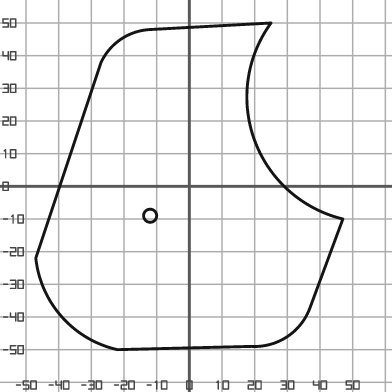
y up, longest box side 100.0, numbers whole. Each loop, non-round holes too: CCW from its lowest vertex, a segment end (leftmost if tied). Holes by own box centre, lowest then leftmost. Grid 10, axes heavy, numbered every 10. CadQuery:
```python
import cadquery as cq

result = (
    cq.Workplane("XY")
    .moveTo(-22.0, -50.0)
    .lineTo(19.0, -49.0)
    .threePointArc((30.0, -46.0), (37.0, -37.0))
    .lineTo(47.0, -10.0)
    .threePointArc((20.0, 14.0), (25.0, 50.0))
    .lineTo(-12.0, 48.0)
    .threePointArc((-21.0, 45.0), (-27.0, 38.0))
    .lineTo(-47.0, -22.0)
    .threePointArc((-39.0, -40.0), (-22.0, -50.0))
    .close()
    .moveTo(-12.0, -9.0)
    .circle(2.0)
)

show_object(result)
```